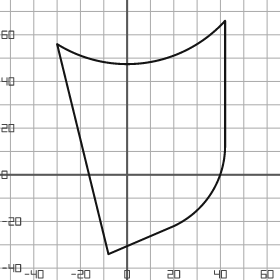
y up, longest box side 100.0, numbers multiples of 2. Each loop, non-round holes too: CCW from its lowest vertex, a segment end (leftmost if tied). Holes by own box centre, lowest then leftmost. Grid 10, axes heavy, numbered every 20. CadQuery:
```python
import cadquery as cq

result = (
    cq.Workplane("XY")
    .moveTo(-8.0, -34.0)
    .lineTo(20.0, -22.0)
    .threePointArc((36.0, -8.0), (42.0, 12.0))
    .lineTo(42.0, 66.0)
    .threePointArc((8.0, 48.0), (-30.0, 56.0))
    .close()
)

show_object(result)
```